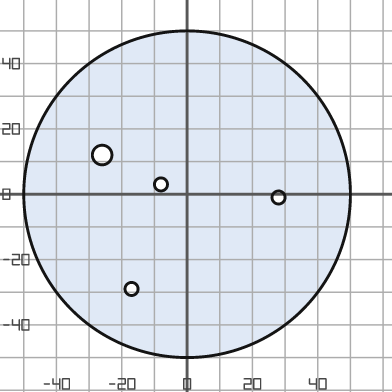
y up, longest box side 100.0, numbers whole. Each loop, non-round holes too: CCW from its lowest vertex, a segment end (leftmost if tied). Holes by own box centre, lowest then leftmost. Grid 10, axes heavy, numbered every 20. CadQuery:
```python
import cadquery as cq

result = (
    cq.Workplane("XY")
    .moveTo(0.0, 0.0)
    .circle(50.0)
    .moveTo(-17.0, -29.0)
    .circle(2.0)
    .moveTo(28.0, -1.0)
    .circle(2.0)
    .moveTo(-8.0, 3.0)
    .circle(2.0)
    .moveTo(-26.0, 12.0)
    .circle(3.0)
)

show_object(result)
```